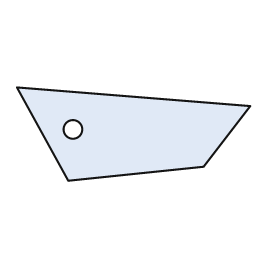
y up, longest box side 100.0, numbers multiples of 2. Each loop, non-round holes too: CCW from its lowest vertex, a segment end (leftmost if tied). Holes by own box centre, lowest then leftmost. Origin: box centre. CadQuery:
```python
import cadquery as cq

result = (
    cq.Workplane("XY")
    .moveTo(-28.0, -20.0)
    .lineTo(30.0, -14.0)
    .lineTo(50.0, 12.0)
    .lineTo(-50.0, 20.0)
    .close()
    .moveTo(-26.0, 2.0)
    .circle(4.0)
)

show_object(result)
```